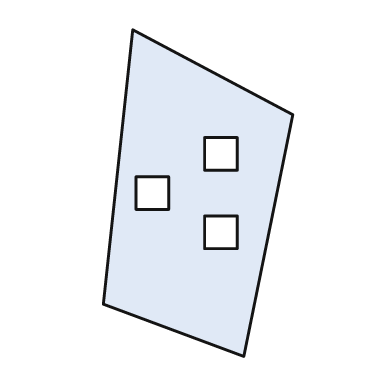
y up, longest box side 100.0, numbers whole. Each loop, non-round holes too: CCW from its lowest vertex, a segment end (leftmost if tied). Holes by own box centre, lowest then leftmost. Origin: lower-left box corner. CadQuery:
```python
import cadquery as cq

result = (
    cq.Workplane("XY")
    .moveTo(43.0, 0.0)
    .lineTo(58.0, 74.0)
    .lineTo(9.0, 100.0)
    .lineTo(0.0, 16.0)
    .close()
    .moveTo(31.0, 33.0)
    .lineTo(41.0, 33.0)
    .lineTo(41.0, 43.0)
    .lineTo(31.0, 43.0)
    .close()
    .moveTo(10.0, 45.0)
    .lineTo(20.0, 45.0)
    .lineTo(20.0, 55.0)
    .lineTo(10.0, 55.0)
    .close()
    .moveTo(31.0, 57.0)
    .lineTo(41.0, 57.0)
    .lineTo(41.0, 67.0)
    .lineTo(31.0, 67.0)
    .close()
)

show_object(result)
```